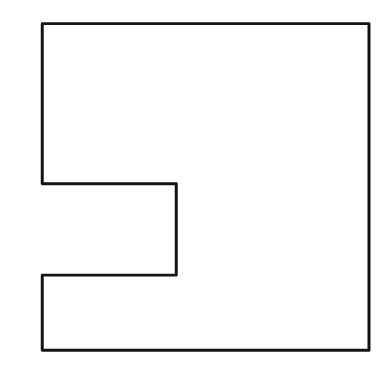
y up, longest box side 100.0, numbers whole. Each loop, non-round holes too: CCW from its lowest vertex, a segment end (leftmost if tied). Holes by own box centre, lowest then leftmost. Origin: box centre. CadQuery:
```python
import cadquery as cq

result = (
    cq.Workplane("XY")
    .moveTo(-50.0, -50.0)
    .lineTo(50.0, -50.0)
    .lineTo(50.0, 50.0)
    .lineTo(-50.0, 50.0)
    .lineTo(-50.0, 1.0)
    .lineTo(-9.0, 1.0)
    .lineTo(-9.0, -27.0)
    .lineTo(-50.0, -27.0)
    .close()
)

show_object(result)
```